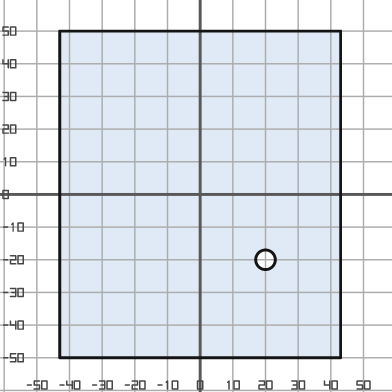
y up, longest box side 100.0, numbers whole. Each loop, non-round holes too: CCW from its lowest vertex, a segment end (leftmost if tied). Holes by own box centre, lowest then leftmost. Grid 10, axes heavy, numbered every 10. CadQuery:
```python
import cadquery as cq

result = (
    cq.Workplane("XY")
    .moveTo(-43.0, -50.0)
    .lineTo(43.0, -50.0)
    .lineTo(43.0, 50.0)
    .lineTo(-43.0, 50.0)
    .close()
    .moveTo(20.0, -20.0)
    .circle(3.0)
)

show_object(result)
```